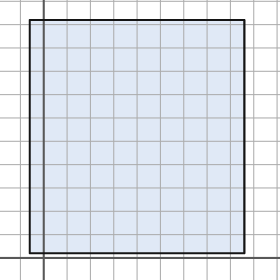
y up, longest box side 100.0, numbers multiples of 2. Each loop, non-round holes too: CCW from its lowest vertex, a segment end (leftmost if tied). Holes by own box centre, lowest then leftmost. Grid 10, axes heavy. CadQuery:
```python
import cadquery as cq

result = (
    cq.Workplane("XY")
    .moveTo(-6.0, 2.0)
    .lineTo(86.0, 2.0)
    .lineTo(86.0, 102.0)
    .lineTo(-6.0, 102.0)
    .close()
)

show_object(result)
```